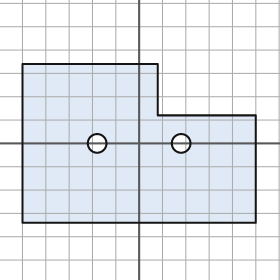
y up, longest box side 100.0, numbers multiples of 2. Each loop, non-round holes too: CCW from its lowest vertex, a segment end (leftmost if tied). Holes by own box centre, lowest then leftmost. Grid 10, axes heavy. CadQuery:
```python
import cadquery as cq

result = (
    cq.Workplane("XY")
    .moveTo(-50.0, -34.0)
    .lineTo(50.0, -34.0)
    .lineTo(50.0, 12.0)
    .lineTo(8.0, 12.0)
    .lineTo(8.0, 34.0)
    .lineTo(-50.0, 34.0)
    .close()
    .moveTo(-18.0, 0.0)
    .circle(4.0)
    .moveTo(18.0, 0.0)
    .circle(4.0)
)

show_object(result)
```